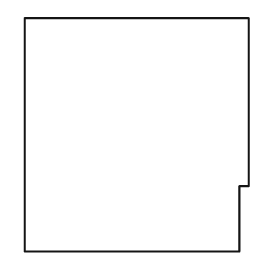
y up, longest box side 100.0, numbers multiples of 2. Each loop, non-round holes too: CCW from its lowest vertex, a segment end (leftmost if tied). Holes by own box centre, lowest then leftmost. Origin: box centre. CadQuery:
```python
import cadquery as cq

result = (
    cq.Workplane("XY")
    .moveTo(-48.0, -50.0)
    .lineTo(44.0, -50.0)
    .lineTo(44.0, -22.0)
    .lineTo(48.0, -22.0)
    .lineTo(48.0, 50.0)
    .lineTo(-48.0, 50.0)
    .close()
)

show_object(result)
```